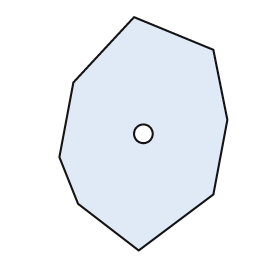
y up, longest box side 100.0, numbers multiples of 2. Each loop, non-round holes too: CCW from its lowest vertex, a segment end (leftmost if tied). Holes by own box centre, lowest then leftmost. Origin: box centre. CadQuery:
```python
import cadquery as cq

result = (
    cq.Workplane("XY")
    .moveTo(-2.0, -50.0)
    .lineTo(30.0, -26.0)
    .lineTo(36.0, 6.0)
    .lineTo(30.0, 36.0)
    .lineTo(-4.0, 50.0)
    .lineTo(-30.0, 22.0)
    .lineTo(-36.0, -10.0)
    .lineTo(-28.0, -30.0)
    .close()
    .moveTo(0.0, 0.0)
    .circle(4.0)
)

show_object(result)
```